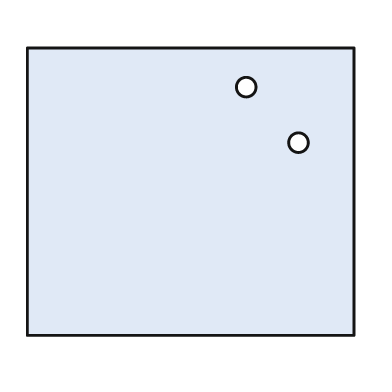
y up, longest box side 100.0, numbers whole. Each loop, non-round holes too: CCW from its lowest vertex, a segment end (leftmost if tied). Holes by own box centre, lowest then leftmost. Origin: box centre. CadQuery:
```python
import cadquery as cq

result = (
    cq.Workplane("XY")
    .moveTo(-50.0, -44.0)
    .lineTo(50.0, -44.0)
    .lineTo(50.0, 44.0)
    .lineTo(-50.0, 44.0)
    .close()
    .moveTo(33.0, 15.0)
    .circle(3.0)
    .moveTo(17.0, 32.0)
    .circle(3.0)
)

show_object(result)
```